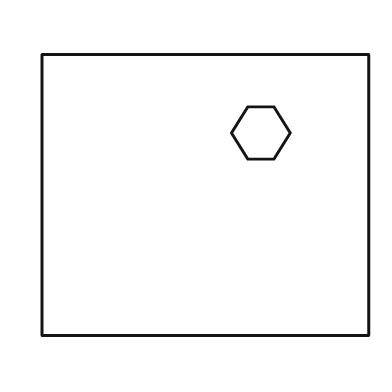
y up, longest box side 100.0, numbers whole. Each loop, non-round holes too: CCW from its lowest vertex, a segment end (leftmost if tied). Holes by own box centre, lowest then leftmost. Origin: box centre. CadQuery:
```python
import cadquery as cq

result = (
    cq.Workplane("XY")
    .moveTo(-50.0, -43.0)
    .lineTo(50.0, -43.0)
    .lineTo(50.0, 43.0)
    .lineTo(-50.0, 43.0)
    .close()
    .moveTo(13.0, 11.0)
    .lineTo(21.0, 11.0)
    .lineTo(26.0, 19.0)
    .lineTo(21.0, 27.0)
    .lineTo(13.0, 27.0)
    .lineTo(8.0, 19.0)
    .close()
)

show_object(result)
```